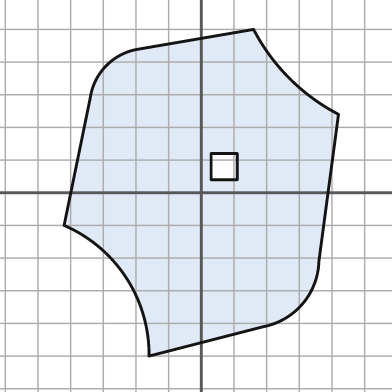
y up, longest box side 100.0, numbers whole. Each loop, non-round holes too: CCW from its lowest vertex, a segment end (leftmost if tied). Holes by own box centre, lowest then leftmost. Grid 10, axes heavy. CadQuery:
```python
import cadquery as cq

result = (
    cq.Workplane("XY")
    .moveTo(-16.0, -50.0)
    .lineTo(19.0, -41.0)
    .threePointArc((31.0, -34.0), (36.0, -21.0))
    .lineTo(42.0, 24.0)
    .threePointArc((27.0, 35.0), (16.0, 50.0))
    .lineTo(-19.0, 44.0)
    .threePointArc((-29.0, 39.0), (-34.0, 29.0))
    .lineTo(-42.0, -10.0)
    .threePointArc((-23.0, -26.0), (-16.0, -50.0))
    .close()
    .moveTo(3.0, 4.0)
    .lineTo(11.0, 4.0)
    .lineTo(11.0, 12.0)
    .lineTo(3.0, 12.0)
    .close()
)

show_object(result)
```